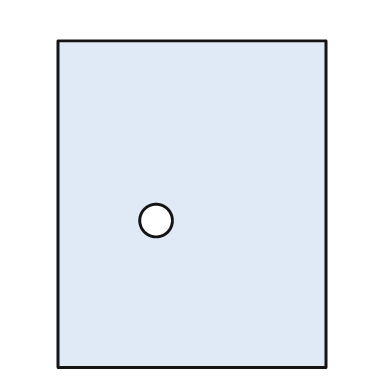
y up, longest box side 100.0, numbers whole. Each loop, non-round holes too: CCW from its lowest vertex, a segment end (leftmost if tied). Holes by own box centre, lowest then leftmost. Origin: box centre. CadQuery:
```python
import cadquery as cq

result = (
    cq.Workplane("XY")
    .moveTo(-41.0, -50.0)
    .lineTo(41.0, -50.0)
    .lineTo(41.0, 50.0)
    .lineTo(-41.0, 50.0)
    .close()
    .moveTo(-11.0, -5.0)
    .circle(5.0)
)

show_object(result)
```